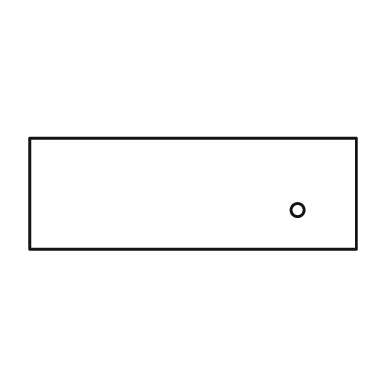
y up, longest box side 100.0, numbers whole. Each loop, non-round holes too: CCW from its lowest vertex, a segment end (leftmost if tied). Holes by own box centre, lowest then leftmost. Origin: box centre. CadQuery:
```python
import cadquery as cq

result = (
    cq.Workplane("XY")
    .moveTo(-50.0, -17.0)
    .lineTo(50.0, -17.0)
    .lineTo(50.0, 17.0)
    .lineTo(-50.0, 17.0)
    .close()
    .moveTo(32.0, -5.0)
    .circle(2.0)
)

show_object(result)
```